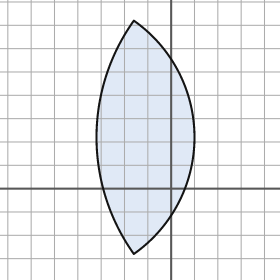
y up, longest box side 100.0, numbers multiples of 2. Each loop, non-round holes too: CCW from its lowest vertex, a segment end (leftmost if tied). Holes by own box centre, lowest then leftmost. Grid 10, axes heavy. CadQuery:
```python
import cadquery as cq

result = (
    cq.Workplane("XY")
    .moveTo(-16.0, -28.0)
    .threePointArc((10.0, 22.0), (-16.0, 72.0))
    .threePointArc((-32.0, 22.0), (-16.0, -28.0))
    .close()
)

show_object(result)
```